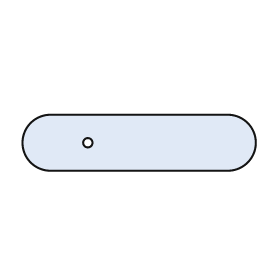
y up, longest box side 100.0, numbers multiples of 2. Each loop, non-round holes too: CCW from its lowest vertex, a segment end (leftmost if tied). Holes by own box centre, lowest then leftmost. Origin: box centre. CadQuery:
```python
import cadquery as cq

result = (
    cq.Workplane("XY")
    .moveTo(-38.0, -12.0)
    .lineTo(38.0, -12.0)
    .threePointArc((50.0, 0.0), (38.0, 12.0))
    .lineTo(-38.0, 12.0)
    .threePointArc((-50.0, 0.0), (-38.0, -12.0))
    .close()
    .moveTo(-22.0, 0.0)
    .circle(2.0)
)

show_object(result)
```